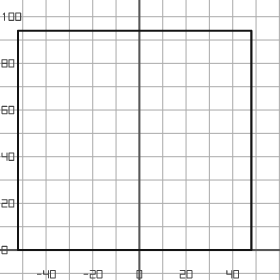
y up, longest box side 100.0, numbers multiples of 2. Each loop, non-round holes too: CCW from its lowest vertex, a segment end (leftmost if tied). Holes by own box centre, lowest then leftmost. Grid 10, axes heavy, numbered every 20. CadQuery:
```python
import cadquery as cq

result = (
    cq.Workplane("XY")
    .moveTo(-52.0, 0.0)
    .lineTo(48.0, 0.0)
    .lineTo(48.0, 94.0)
    .lineTo(-52.0, 94.0)
    .close()
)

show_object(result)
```